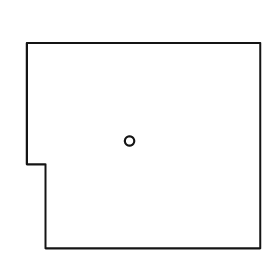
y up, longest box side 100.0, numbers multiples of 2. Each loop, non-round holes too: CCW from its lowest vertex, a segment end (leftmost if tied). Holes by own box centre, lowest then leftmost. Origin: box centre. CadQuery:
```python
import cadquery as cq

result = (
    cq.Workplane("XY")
    .moveTo(-42.0, -44.0)
    .lineTo(50.0, -44.0)
    .lineTo(50.0, 44.0)
    .lineTo(-50.0, 44.0)
    .lineTo(-50.0, -8.0)
    .lineTo(-42.0, -8.0)
    .close()
    .moveTo(-6.0, 2.0)
    .circle(2.0)
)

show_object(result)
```